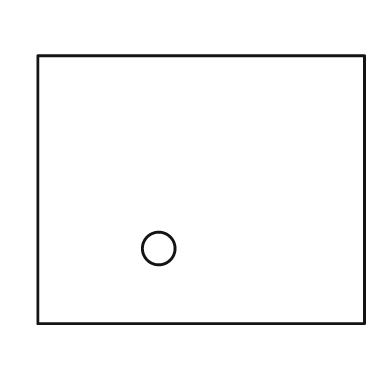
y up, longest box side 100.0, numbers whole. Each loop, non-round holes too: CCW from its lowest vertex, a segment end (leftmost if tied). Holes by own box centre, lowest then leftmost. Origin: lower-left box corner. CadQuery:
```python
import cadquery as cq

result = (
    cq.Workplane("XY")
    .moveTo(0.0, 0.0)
    .lineTo(100.0, 0.0)
    .lineTo(100.0, 82.0)
    .lineTo(0.0, 82.0)
    .close()
    .moveTo(37.0, 23.0)
    .circle(5.0)
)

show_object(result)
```